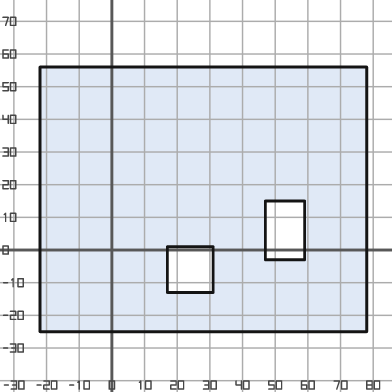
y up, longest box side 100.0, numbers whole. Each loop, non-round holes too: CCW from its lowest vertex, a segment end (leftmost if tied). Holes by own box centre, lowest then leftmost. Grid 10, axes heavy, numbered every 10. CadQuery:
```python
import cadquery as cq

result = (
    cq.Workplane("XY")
    .moveTo(-22.0, -25.0)
    .lineTo(78.0, -25.0)
    .lineTo(78.0, 56.0)
    .lineTo(-22.0, 56.0)
    .close()
    .moveTo(17.0, -13.0)
    .lineTo(31.0, -13.0)
    .lineTo(31.0, 1.0)
    .lineTo(17.0, 1.0)
    .close()
    .moveTo(47.0, -3.0)
    .lineTo(59.0, -3.0)
    .lineTo(59.0, 15.0)
    .lineTo(47.0, 15.0)
    .close()
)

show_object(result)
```